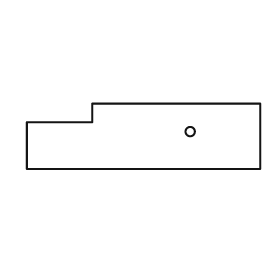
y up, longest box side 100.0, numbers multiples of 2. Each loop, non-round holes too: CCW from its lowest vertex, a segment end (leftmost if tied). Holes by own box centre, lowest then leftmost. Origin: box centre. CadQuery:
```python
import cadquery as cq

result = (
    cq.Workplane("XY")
    .moveTo(-50.0, -14.0)
    .lineTo(50.0, -14.0)
    .lineTo(50.0, 14.0)
    .lineTo(-22.0, 14.0)
    .lineTo(-22.0, 6.0)
    .lineTo(-50.0, 6.0)
    .close()
    .moveTo(20.0, 2.0)
    .circle(2.0)
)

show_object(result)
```